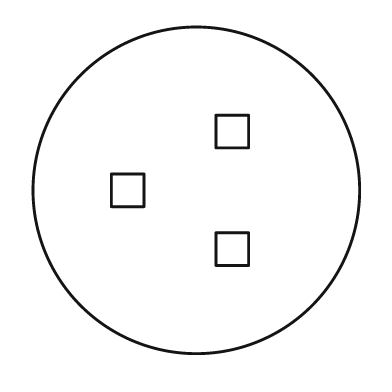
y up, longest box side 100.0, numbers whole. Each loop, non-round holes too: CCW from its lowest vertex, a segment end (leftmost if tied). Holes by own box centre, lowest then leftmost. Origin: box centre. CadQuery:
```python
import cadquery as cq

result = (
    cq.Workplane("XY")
    .moveTo(0.0, 0.0)
    .circle(50.0)
    .moveTo(6.0, -23.0)
    .lineTo(16.0, -23.0)
    .lineTo(16.0, -13.0)
    .lineTo(6.0, -13.0)
    .close()
    .moveTo(-26.0, -5.0)
    .lineTo(-16.0, -5.0)
    .lineTo(-16.0, 5.0)
    .lineTo(-26.0, 5.0)
    .close()
    .moveTo(6.0, 13.0)
    .lineTo(16.0, 13.0)
    .lineTo(16.0, 23.0)
    .lineTo(6.0, 23.0)
    .close()
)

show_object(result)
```